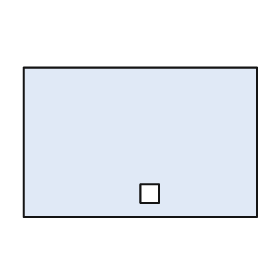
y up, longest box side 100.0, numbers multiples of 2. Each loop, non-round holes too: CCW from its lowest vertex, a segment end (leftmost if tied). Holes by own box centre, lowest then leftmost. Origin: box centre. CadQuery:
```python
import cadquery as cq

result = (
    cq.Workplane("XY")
    .moveTo(-50.0, -32.0)
    .lineTo(50.0, -32.0)
    .lineTo(50.0, 32.0)
    .lineTo(-50.0, 32.0)
    .close()
    .moveTo(0.0, -26.0)
    .lineTo(8.0, -26.0)
    .lineTo(8.0, -18.0)
    .lineTo(0.0, -18.0)
    .close()
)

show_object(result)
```